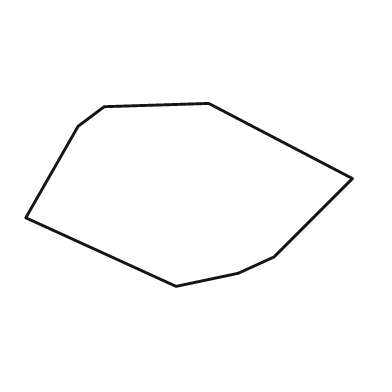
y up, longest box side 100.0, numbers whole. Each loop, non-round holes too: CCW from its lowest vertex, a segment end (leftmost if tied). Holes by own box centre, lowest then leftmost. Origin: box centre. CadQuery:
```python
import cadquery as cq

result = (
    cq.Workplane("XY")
    .moveTo(-4.0, -28.0)
    .lineTo(15.0, -24.0)
    .lineTo(26.0, -19.0)
    .lineTo(50.0, 5.0)
    .lineTo(6.0, 28.0)
    .lineTo(-26.0, 27.0)
    .lineTo(-34.0, 21.0)
    .lineTo(-50.0, -7.0)
    .close()
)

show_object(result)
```